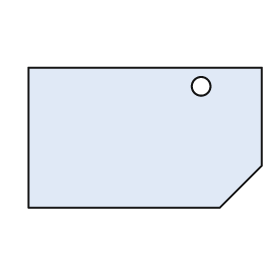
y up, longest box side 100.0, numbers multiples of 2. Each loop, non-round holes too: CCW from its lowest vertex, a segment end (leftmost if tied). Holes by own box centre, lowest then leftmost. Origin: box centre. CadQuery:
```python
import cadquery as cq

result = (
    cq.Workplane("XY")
    .moveTo(-50.0, -30.0)
    .lineTo(32.0, -30.0)
    .lineTo(50.0, -12.0)
    .lineTo(50.0, 30.0)
    .lineTo(-50.0, 30.0)
    .close()
    .moveTo(24.0, 22.0)
    .circle(4.0)
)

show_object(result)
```